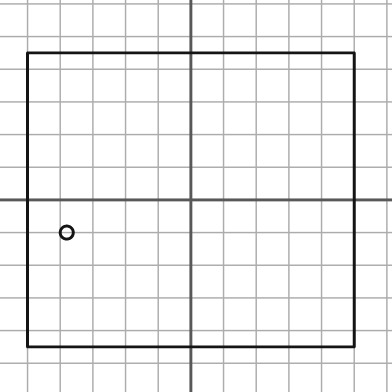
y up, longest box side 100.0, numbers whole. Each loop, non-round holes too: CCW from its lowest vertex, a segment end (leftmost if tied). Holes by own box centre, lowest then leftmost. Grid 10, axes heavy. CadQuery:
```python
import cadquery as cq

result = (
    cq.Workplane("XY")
    .moveTo(-50.0, -45.0)
    .lineTo(50.0, -45.0)
    .lineTo(50.0, 45.0)
    .lineTo(-50.0, 45.0)
    .close()
    .moveTo(-38.0, -10.0)
    .circle(2.0)
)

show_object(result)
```